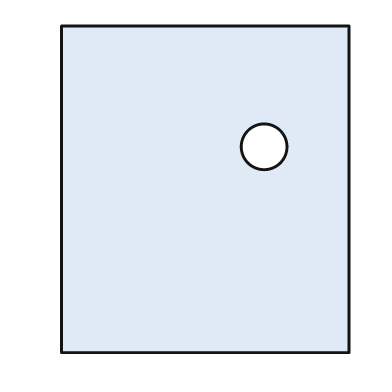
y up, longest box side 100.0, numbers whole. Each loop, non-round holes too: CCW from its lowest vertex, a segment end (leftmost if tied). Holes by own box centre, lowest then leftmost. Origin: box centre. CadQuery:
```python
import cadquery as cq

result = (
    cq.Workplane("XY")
    .moveTo(-44.0, -50.0)
    .lineTo(44.0, -50.0)
    .lineTo(44.0, 50.0)
    .lineTo(-44.0, 50.0)
    .close()
    .moveTo(18.0, 13.0)
    .circle(7.0)
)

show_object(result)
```